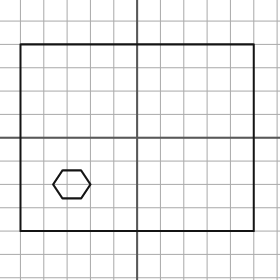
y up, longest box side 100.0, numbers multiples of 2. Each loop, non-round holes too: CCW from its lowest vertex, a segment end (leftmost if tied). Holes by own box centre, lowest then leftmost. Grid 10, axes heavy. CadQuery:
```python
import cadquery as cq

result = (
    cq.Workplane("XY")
    .moveTo(-50.0, -40.0)
    .lineTo(50.0, -40.0)
    .lineTo(50.0, 40.0)
    .lineTo(-50.0, 40.0)
    .close()
    .moveTo(-32.0, -26.0)
    .lineTo(-24.0, -26.0)
    .lineTo(-20.0, -20.0)
    .lineTo(-24.0, -14.0)
    .lineTo(-32.0, -14.0)
    .lineTo(-36.0, -20.0)
    .close()
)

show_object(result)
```